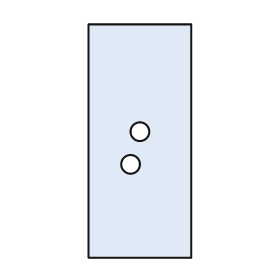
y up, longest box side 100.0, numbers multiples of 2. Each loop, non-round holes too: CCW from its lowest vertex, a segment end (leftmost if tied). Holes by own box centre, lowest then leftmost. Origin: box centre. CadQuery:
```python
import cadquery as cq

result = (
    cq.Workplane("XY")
    .moveTo(-22.0, -50.0)
    .lineTo(22.0, -50.0)
    .lineTo(22.0, 50.0)
    .lineTo(-22.0, 50.0)
    .close()
    .moveTo(-4.0, -10.0)
    .circle(4.0)
    .moveTo(0.0, 4.0)
    .circle(4.0)
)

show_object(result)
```